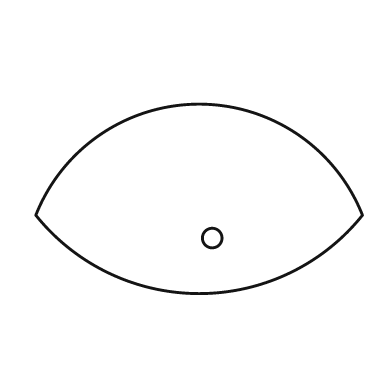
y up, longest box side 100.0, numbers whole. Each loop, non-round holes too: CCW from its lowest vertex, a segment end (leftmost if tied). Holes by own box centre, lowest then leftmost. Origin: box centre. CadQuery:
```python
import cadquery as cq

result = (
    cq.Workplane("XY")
    .moveTo(-50.0, -5.0)
    .threePointArc((0.0, -29.0), (50.0, -5.0))
    .threePointArc((0.0, 29.0), (-50.0, -5.0))
    .close()
    .moveTo(4.0, -12.0)
    .circle(3.0)
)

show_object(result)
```